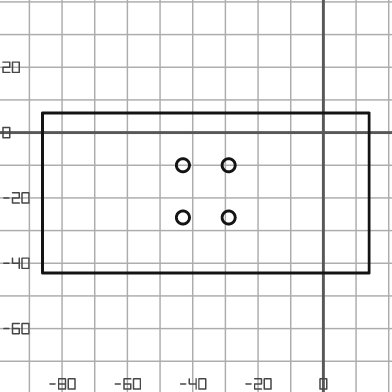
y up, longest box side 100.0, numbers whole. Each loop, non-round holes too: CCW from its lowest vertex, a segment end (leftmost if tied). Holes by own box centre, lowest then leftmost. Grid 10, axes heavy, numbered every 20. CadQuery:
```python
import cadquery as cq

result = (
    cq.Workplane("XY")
    .moveTo(-86.0, -43.0)
    .lineTo(14.0, -43.0)
    .lineTo(14.0, 6.0)
    .lineTo(-86.0, 6.0)
    .close()
    .moveTo(-43.0, -26.0)
    .circle(2.0)
    .moveTo(-29.0, -26.0)
    .circle(2.0)
    .moveTo(-43.0, -10.0)
    .circle(2.0)
    .moveTo(-29.0, -10.0)
    .circle(2.0)
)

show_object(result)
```